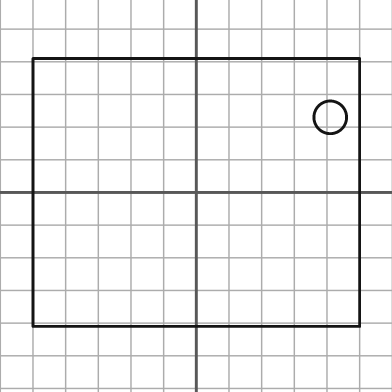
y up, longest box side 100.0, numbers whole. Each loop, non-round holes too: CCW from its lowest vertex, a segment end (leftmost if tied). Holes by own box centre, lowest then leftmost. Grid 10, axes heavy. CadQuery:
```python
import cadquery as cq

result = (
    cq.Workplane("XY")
    .moveTo(-50.0, -41.0)
    .lineTo(50.0, -41.0)
    .lineTo(50.0, 41.0)
    .lineTo(-50.0, 41.0)
    .close()
    .moveTo(41.0, 23.0)
    .circle(5.0)
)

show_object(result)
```